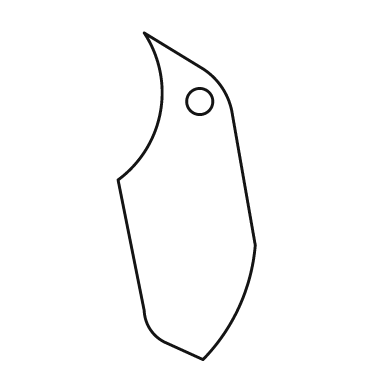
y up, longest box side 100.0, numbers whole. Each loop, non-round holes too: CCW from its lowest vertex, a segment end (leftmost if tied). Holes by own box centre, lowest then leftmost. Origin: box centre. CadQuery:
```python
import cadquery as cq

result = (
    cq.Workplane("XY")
    .moveTo(5.0, -50.0)
    .threePointArc((16.0, -34.0), (21.0, -15.0))
    .lineTo(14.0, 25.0)
    .threePointArc((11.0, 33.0), (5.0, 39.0))
    .lineTo(-13.0, 50.0)
    .threePointArc((-8.0, 26.0), (-21.0, 5.0))
    .lineTo(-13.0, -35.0)
    .threePointArc((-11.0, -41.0), (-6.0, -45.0))
    .close()
    .moveTo(4.0, 29.0)
    .circle(4.0)
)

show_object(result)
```